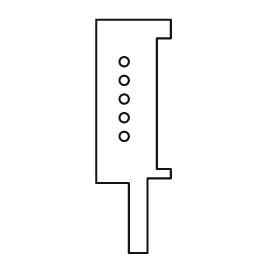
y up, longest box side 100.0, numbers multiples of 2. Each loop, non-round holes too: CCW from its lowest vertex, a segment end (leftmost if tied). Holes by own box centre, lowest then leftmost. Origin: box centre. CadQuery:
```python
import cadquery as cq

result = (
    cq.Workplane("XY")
    .moveTo(-2.0, -50.0)
    .lineTo(6.0, -50.0)
    .lineTo(6.0, -18.0)
    .lineTo(16.0, -18.0)
    .lineTo(16.0, -14.0)
    .lineTo(10.0, -14.0)
    .lineTo(10.0, 42.0)
    .lineTo(16.0, 42.0)
    .lineTo(16.0, 50.0)
    .lineTo(-16.0, 50.0)
    .lineTo(-16.0, -20.0)
    .lineTo(-2.0, -20.0)
    .close()
    .moveTo(-4.0, 0.0)
    .circle(2.0)
    .moveTo(-4.0, 8.0)
    .circle(2.0)
    .moveTo(-4.0, 16.0)
    .circle(2.0)
    .moveTo(-4.0, 24.0)
    .circle(2.0)
    .moveTo(-4.0, 32.0)
    .circle(2.0)
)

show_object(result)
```